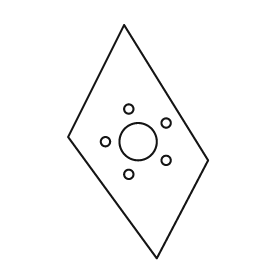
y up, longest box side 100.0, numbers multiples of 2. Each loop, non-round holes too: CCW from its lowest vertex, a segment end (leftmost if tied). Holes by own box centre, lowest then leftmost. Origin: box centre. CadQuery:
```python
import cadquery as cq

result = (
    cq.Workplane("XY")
    .moveTo(8.0, -50.0)
    .lineTo(30.0, -8.0)
    .lineTo(-6.0, 50.0)
    .lineTo(-30.0, 2.0)
    .close()
    .moveTo(-4.0, -14.0)
    .circle(2.0)
    .moveTo(12.0, -8.0)
    .circle(2.0)
    .moveTo(-14.0, 0.0)
    .circle(2.0)
    .moveTo(0.0, 0.0)
    .circle(8.0)
    .moveTo(12.0, 8.0)
    .circle(2.0)
    .moveTo(-4.0, 14.0)
    .circle(2.0)
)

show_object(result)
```